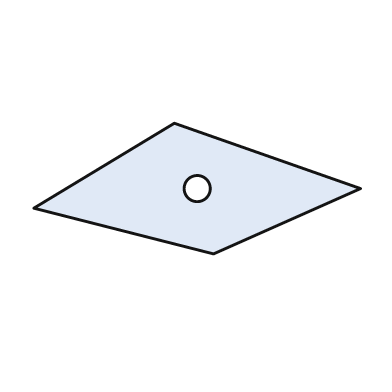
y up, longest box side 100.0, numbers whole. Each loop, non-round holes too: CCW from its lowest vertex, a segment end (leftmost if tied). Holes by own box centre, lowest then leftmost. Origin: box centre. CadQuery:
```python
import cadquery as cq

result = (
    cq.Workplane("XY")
    .moveTo(5.0, -20.0)
    .lineTo(50.0, 0.0)
    .lineTo(-7.0, 20.0)
    .lineTo(-50.0, -6.0)
    .close()
    .moveTo(0.0, 0.0)
    .circle(4.0)
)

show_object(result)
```